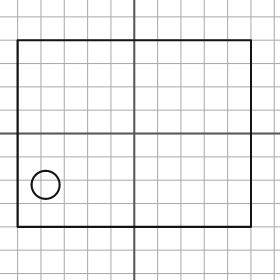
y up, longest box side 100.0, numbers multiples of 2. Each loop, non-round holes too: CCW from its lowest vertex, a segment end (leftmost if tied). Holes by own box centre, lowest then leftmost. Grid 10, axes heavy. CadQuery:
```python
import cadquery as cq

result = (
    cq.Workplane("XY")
    .moveTo(-50.0, -40.0)
    .lineTo(50.0, -40.0)
    .lineTo(50.0, 40.0)
    .lineTo(-50.0, 40.0)
    .close()
    .moveTo(-38.0, -22.0)
    .circle(6.0)
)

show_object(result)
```